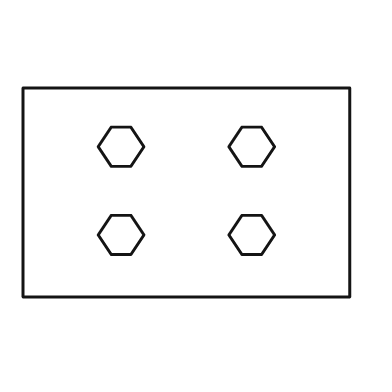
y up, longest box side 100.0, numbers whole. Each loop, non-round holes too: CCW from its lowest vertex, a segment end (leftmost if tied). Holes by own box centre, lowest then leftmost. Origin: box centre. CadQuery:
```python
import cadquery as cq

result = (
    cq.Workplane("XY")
    .moveTo(-50.0, -32.0)
    .lineTo(50.0, -32.0)
    .lineTo(50.0, 32.0)
    .lineTo(-50.0, 32.0)
    .close()
    .moveTo(-23.0, -19.0)
    .lineTo(-17.0, -19.0)
    .lineTo(-13.0, -13.0)
    .lineTo(-17.0, -7.0)
    .lineTo(-23.0, -7.0)
    .lineTo(-27.0, -13.0)
    .close()
    .moveTo(17.0, -19.0)
    .lineTo(23.0, -19.0)
    .lineTo(27.0, -13.0)
    .lineTo(23.0, -7.0)
    .lineTo(17.0, -7.0)
    .lineTo(13.0, -13.0)
    .close()
    .moveTo(-23.0, 8.0)
    .lineTo(-17.0, 8.0)
    .lineTo(-13.0, 14.0)
    .lineTo(-17.0, 20.0)
    .lineTo(-23.0, 20.0)
    .lineTo(-27.0, 14.0)
    .close()
    .moveTo(17.0, 8.0)
    .lineTo(23.0, 8.0)
    .lineTo(27.0, 14.0)
    .lineTo(23.0, 20.0)
    .lineTo(17.0, 20.0)
    .lineTo(13.0, 14.0)
    .close()
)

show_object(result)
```